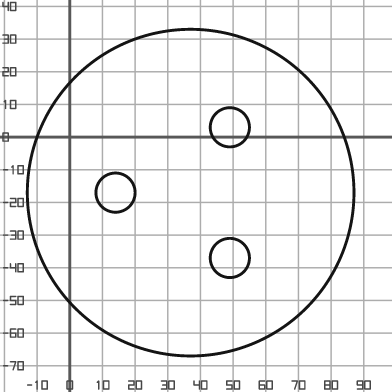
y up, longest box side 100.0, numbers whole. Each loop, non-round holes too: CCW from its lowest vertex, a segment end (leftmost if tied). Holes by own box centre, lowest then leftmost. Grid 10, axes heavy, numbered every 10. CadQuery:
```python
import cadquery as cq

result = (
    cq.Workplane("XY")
    .moveTo(37.0, -17.0)
    .circle(50.0)
    .moveTo(49.0, -37.0)
    .circle(6.0)
    .moveTo(14.0, -17.0)
    .circle(6.0)
    .moveTo(49.0, 3.0)
    .circle(6.0)
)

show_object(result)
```